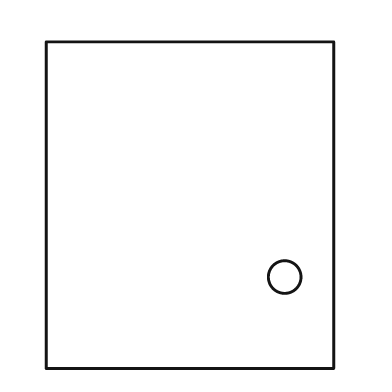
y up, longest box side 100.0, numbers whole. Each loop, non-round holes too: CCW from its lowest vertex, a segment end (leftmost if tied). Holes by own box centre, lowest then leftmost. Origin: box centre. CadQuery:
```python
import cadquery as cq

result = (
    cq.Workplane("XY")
    .moveTo(-44.0, -50.0)
    .lineTo(44.0, -50.0)
    .lineTo(44.0, 50.0)
    .lineTo(-44.0, 50.0)
    .close()
    .moveTo(29.0, -22.0)
    .circle(5.0)
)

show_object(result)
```